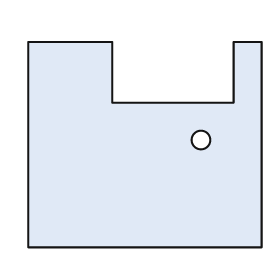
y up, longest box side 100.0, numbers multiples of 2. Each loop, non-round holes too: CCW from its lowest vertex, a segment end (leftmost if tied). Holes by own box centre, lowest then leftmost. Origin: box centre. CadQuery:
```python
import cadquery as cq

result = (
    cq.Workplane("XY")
    .moveTo(-50.0, -44.0)
    .lineTo(50.0, -44.0)
    .lineTo(50.0, 44.0)
    .lineTo(38.0, 44.0)
    .lineTo(38.0, 18.0)
    .lineTo(-14.0, 18.0)
    .lineTo(-14.0, 44.0)
    .lineTo(-50.0, 44.0)
    .close()
    .moveTo(24.0, 2.0)
    .circle(4.0)
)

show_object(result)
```